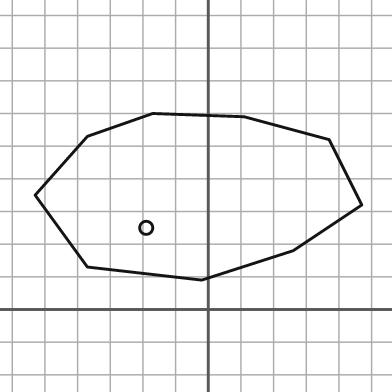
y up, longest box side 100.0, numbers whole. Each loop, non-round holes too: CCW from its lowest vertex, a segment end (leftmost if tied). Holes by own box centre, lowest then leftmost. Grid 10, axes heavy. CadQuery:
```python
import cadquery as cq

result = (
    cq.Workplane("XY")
    .moveTo(-2.0, 9.0)
    .lineTo(26.0, 18.0)
    .lineTo(47.0, 32.0)
    .lineTo(37.0, 52.0)
    .lineTo(11.0, 59.0)
    .lineTo(-17.0, 60.0)
    .lineTo(-37.0, 53.0)
    .lineTo(-53.0, 35.0)
    .lineTo(-37.0, 13.0)
    .close()
    .moveTo(-19.0, 25.0)
    .circle(2.0)
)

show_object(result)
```